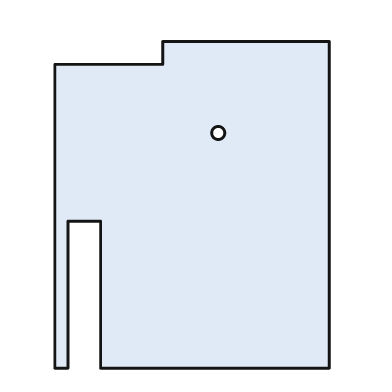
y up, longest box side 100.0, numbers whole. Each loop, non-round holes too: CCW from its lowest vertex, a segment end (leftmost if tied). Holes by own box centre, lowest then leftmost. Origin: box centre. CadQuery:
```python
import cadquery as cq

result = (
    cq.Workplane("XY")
    .moveTo(-42.0, -50.0)
    .lineTo(-38.0, -50.0)
    .lineTo(-38.0, -5.0)
    .lineTo(-28.0, -5.0)
    .lineTo(-28.0, -50.0)
    .lineTo(42.0, -50.0)
    .lineTo(42.0, 50.0)
    .lineTo(-9.0, 50.0)
    .lineTo(-9.0, 43.0)
    .lineTo(-42.0, 43.0)
    .close()
    .moveTo(8.0, 22.0)
    .circle(2.0)
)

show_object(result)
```